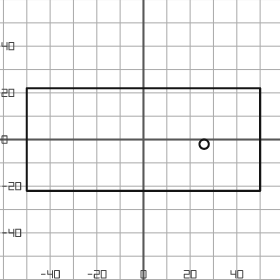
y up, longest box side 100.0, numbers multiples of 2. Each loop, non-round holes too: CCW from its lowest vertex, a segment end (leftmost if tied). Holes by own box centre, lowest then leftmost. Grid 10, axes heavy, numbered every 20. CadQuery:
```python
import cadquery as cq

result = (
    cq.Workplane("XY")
    .moveTo(-50.0, -22.0)
    .lineTo(50.0, -22.0)
    .lineTo(50.0, 22.0)
    .lineTo(-50.0, 22.0)
    .close()
    .moveTo(26.0, -2.0)
    .circle(2.0)
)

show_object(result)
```